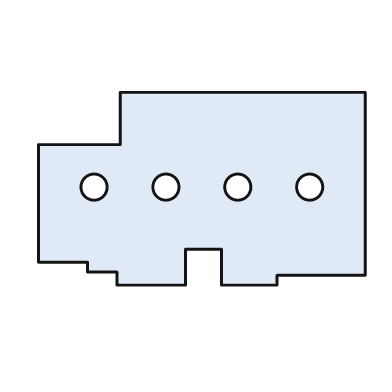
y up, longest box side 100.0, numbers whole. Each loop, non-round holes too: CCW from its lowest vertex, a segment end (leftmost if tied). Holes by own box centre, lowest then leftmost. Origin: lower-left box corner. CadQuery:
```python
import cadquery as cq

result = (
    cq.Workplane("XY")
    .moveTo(24.0, 0.0)
    .lineTo(45.0, 0.0)
    .lineTo(45.0, 11.0)
    .lineTo(56.0, 11.0)
    .lineTo(56.0, 0.0)
    .lineTo(73.0, 0.0)
    .lineTo(73.0, 3.0)
    .lineTo(100.0, 3.0)
    .lineTo(100.0, 59.0)
    .lineTo(25.0, 59.0)
    .lineTo(25.0, 43.0)
    .lineTo(0.0, 43.0)
    .lineTo(0.0, 7.0)
    .lineTo(15.0, 7.0)
    .lineTo(15.0, 4.0)
    .lineTo(24.0, 4.0)
    .close()
    .moveTo(17.0, 30.0)
    .circle(4.0)
    .moveTo(39.0, 30.0)
    .circle(4.0)
    .moveTo(61.0, 30.0)
    .circle(4.0)
    .moveTo(83.0, 30.0)
    .circle(4.0)
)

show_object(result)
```